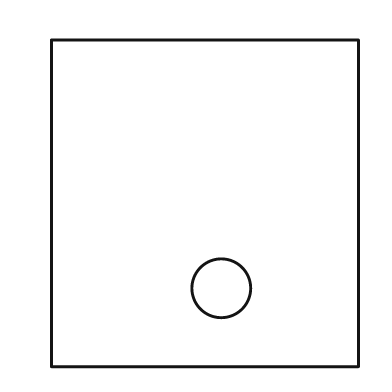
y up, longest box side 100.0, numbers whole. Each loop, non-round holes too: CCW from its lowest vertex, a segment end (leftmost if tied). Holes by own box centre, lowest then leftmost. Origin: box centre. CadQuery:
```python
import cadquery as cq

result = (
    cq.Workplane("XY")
    .moveTo(-47.0, -50.0)
    .lineTo(47.0, -50.0)
    .lineTo(47.0, 50.0)
    .lineTo(-47.0, 50.0)
    .close()
    .moveTo(5.0, -26.0)
    .circle(9.0)
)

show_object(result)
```